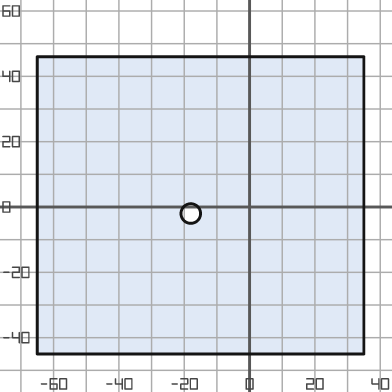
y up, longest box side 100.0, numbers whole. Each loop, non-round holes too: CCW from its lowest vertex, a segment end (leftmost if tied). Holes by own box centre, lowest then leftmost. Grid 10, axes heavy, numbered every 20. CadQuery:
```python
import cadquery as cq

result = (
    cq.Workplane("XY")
    .moveTo(-65.0, -45.0)
    .lineTo(35.0, -45.0)
    .lineTo(35.0, 46.0)
    .lineTo(-65.0, 46.0)
    .close()
    .moveTo(-18.0, -2.0)
    .circle(3.0)
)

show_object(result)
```